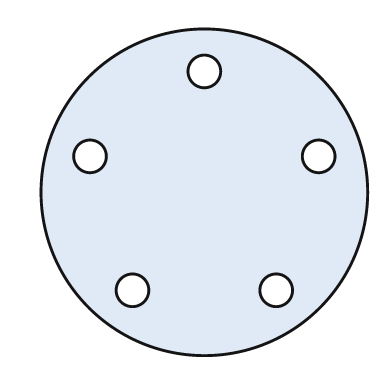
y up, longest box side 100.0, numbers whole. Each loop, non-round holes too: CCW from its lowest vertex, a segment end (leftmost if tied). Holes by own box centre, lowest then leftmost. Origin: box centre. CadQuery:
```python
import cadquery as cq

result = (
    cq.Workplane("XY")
    .moveTo(0.0, 0.0)
    .circle(50.0)
    .moveTo(-22.0, -30.0)
    .circle(5.0)
    .moveTo(22.0, -30.0)
    .circle(5.0)
    .moveTo(-35.0, 11.0)
    .circle(5.0)
    .moveTo(35.0, 11.0)
    .circle(5.0)
    .moveTo(0.0, 37.0)
    .circle(5.0)
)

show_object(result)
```